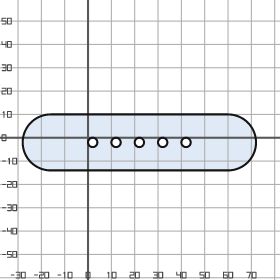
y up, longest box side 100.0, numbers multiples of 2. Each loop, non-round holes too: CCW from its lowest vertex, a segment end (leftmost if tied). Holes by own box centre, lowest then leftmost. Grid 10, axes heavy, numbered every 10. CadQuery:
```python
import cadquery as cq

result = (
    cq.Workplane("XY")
    .moveTo(-16.0, -14.0)
    .lineTo(60.0, -14.0)
    .threePointArc((72.0, -2.0), (60.0, 10.0))
    .lineTo(-16.0, 10.0)
    .threePointArc((-28.0, -2.0), (-16.0, -14.0))
    .close()
    .moveTo(2.0, -2.0)
    .circle(2.0)
    .moveTo(12.0, -2.0)
    .circle(2.0)
    .moveTo(22.0, -2.0)
    .circle(2.0)
    .moveTo(32.0, -2.0)
    .circle(2.0)
    .moveTo(42.0, -2.0)
    .circle(2.0)
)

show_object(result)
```